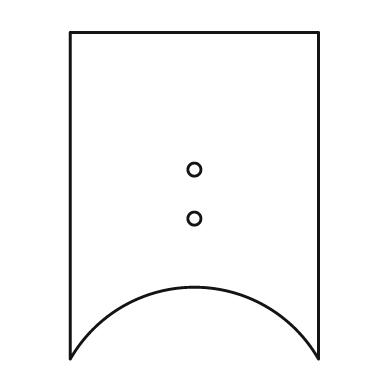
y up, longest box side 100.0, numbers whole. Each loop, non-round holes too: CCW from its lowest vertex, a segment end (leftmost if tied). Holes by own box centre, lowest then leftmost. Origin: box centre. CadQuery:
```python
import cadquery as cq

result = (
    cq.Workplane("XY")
    .moveTo(-38.0, -50.0)
    .threePointArc((0.0, -28.0), (38.0, -50.0))
    .lineTo(38.0, 50.0)
    .lineTo(-38.0, 50.0)
    .close()
    .moveTo(0.0, -7.0)
    .circle(2.0)
    .moveTo(0.0, 8.0)
    .circle(2.0)
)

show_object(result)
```